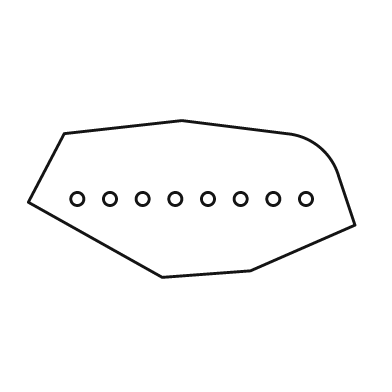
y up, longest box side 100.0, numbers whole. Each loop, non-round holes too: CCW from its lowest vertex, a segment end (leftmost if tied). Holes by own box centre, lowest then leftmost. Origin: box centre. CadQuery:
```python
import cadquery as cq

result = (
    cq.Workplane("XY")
    .moveTo(-9.0, -24.0)
    .lineTo(18.0, -22.0)
    .lineTo(50.0, -8.0)
    .lineTo(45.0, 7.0)
    .threePointArc((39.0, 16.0), (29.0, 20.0))
    .lineTo(-3.0, 24.0)
    .lineTo(-39.0, 20.0)
    .lineTo(-50.0, -1.0)
    .close()
    .moveTo(-35.0, 0.0)
    .circle(2.0)
    .moveTo(-25.0, 0.0)
    .circle(2.0)
    .moveTo(-15.0, 0.0)
    .circle(2.0)
    .moveTo(-5.0, 0.0)
    .circle(2.0)
    .moveTo(5.0, 0.0)
    .circle(2.0)
    .moveTo(15.0, 0.0)
    .circle(2.0)
    .moveTo(25.0, 0.0)
    .circle(2.0)
    .moveTo(35.0, 0.0)
    .circle(2.0)
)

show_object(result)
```